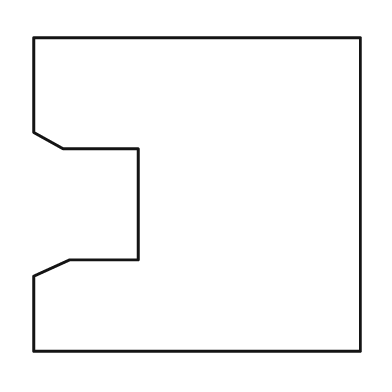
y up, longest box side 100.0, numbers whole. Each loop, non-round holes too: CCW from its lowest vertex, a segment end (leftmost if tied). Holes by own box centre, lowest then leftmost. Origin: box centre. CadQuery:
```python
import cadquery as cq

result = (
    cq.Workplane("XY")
    .moveTo(-50.0, -48.0)
    .lineTo(50.0, -48.0)
    .lineTo(50.0, 48.0)
    .lineTo(-50.0, 48.0)
    .lineTo(-50.0, 19.0)
    .lineTo(-41.0, 14.0)
    .lineTo(-18.0, 14.0)
    .lineTo(-18.0, -20.0)
    .lineTo(-39.0, -20.0)
    .lineTo(-50.0, -25.0)
    .close()
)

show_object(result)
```